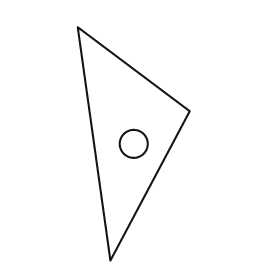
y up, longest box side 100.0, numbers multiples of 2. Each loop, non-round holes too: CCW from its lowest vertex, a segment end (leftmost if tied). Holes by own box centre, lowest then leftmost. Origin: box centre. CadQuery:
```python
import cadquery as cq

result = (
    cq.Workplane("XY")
    .moveTo(-10.0, -50.0)
    .lineTo(24.0, 14.0)
    .lineTo(-24.0, 50.0)
    .close()
    .moveTo(0.0, 0.0)
    .circle(6.0)
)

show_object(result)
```